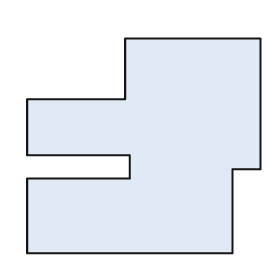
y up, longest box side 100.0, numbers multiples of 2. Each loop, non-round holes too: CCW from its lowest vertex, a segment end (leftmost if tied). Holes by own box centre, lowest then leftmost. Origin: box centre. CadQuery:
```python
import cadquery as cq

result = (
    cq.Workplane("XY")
    .moveTo(-50.0, -46.0)
    .lineTo(38.0, -46.0)
    .lineTo(38.0, -10.0)
    .lineTo(50.0, -10.0)
    .lineTo(50.0, 46.0)
    .lineTo(-8.0, 46.0)
    .lineTo(-8.0, 20.0)
    .lineTo(-50.0, 20.0)
    .lineTo(-50.0, -4.0)
    .lineTo(-6.0, -4.0)
    .lineTo(-6.0, -14.0)
    .lineTo(-50.0, -14.0)
    .close()
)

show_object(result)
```